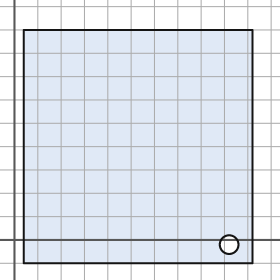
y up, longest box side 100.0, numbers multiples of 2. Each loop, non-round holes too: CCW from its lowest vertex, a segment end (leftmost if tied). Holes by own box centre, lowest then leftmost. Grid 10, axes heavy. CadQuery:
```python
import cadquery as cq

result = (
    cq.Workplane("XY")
    .moveTo(4.0, -10.0)
    .lineTo(102.0, -10.0)
    .lineTo(102.0, 90.0)
    .lineTo(4.0, 90.0)
    .close()
    .moveTo(92.0, -2.0)
    .circle(4.0)
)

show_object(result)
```